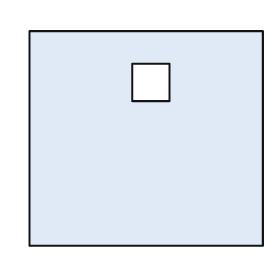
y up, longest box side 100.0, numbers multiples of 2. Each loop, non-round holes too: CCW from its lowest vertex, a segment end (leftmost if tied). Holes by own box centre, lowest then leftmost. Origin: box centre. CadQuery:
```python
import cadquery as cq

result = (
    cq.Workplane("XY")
    .moveTo(-50.0, -46.0)
    .lineTo(50.0, -46.0)
    .lineTo(50.0, 46.0)
    .lineTo(-50.0, 46.0)
    .close()
    .moveTo(-6.0, 16.0)
    .lineTo(10.0, 16.0)
    .lineTo(10.0, 32.0)
    .lineTo(-6.0, 32.0)
    .close()
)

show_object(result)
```